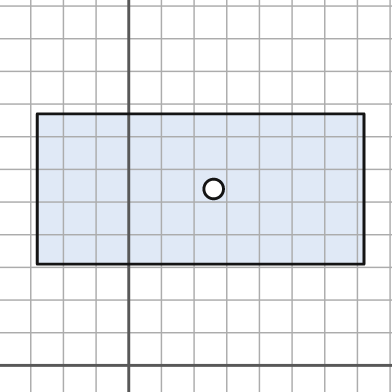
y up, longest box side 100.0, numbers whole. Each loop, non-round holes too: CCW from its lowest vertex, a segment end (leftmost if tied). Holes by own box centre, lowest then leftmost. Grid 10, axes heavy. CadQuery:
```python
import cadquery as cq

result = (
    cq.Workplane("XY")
    .moveTo(-28.0, 31.0)
    .lineTo(72.0, 31.0)
    .lineTo(72.0, 77.0)
    .lineTo(-28.0, 77.0)
    .close()
    .moveTo(26.0, 54.0)
    .circle(3.0)
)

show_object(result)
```